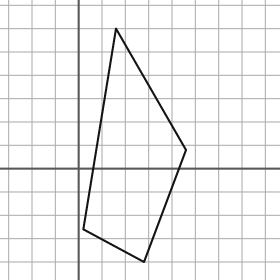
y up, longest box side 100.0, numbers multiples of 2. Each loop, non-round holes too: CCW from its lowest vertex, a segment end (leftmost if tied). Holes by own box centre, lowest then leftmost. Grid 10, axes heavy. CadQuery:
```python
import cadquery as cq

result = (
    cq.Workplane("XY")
    .moveTo(28.0, -40.0)
    .lineTo(46.0, 8.0)
    .lineTo(16.0, 60.0)
    .lineTo(2.0, -26.0)
    .close()
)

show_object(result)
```